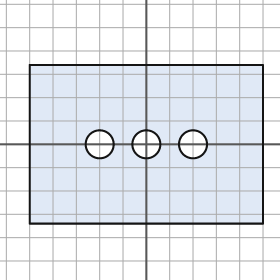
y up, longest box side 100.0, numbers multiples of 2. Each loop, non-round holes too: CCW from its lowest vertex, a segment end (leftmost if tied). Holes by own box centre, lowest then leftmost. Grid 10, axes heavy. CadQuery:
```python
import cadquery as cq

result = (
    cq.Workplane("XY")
    .moveTo(-50.0, -34.0)
    .lineTo(50.0, -34.0)
    .lineTo(50.0, 34.0)
    .lineTo(-50.0, 34.0)
    .close()
    .moveTo(-20.0, 0.0)
    .circle(6.0)
    .moveTo(0.0, 0.0)
    .circle(6.0)
    .moveTo(20.0, 0.0)
    .circle(6.0)
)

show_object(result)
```